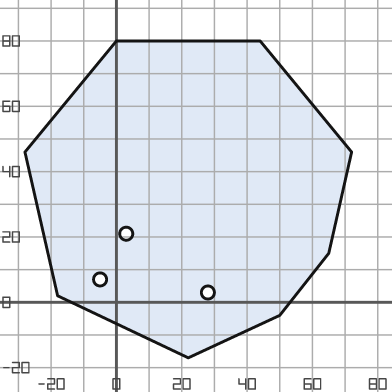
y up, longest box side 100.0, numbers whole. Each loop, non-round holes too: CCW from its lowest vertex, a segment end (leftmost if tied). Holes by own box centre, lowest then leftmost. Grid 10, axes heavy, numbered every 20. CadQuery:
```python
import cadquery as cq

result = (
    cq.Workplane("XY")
    .moveTo(22.0, -17.0)
    .lineTo(50.0, -4.0)
    .lineTo(65.0, 15.0)
    .lineTo(72.0, 46.0)
    .lineTo(44.0, 80.0)
    .lineTo(0.0, 80.0)
    .lineTo(-28.0, 46.0)
    .lineTo(-18.0, 2.0)
    .close()
    .moveTo(28.0, 3.0)
    .circle(2.0)
    .moveTo(-5.0, 7.0)
    .circle(2.0)
    .moveTo(3.0, 21.0)
    .circle(2.0)
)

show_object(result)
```